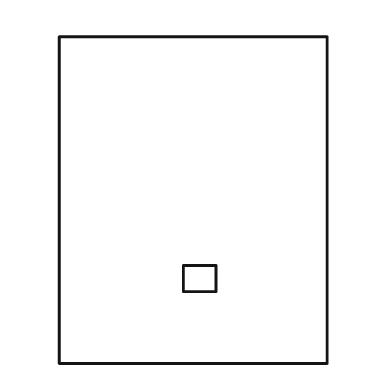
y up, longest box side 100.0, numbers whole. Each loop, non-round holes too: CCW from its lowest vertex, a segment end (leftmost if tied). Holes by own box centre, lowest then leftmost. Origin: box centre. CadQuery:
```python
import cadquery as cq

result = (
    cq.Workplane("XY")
    .moveTo(-41.0, -50.0)
    .lineTo(41.0, -50.0)
    .lineTo(41.0, 50.0)
    .lineTo(-41.0, 50.0)
    .close()
    .moveTo(-3.0, -28.0)
    .lineTo(7.0, -28.0)
    .lineTo(7.0, -20.0)
    .lineTo(-3.0, -20.0)
    .close()
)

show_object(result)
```